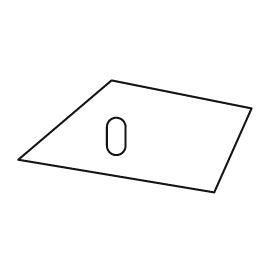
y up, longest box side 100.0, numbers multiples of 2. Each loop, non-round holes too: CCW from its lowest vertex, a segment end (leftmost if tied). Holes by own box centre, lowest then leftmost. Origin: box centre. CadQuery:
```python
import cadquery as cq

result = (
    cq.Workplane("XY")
    .moveTo(34.0, -24.0)
    .lineTo(50.0, 12.0)
    .lineTo(-10.0, 24.0)
    .lineTo(-50.0, -10.0)
    .close()
    .moveTo(-12.0, -4.0)
    .threePointArc((-8.0, -8.0), (-4.0, -4.0))
    .lineTo(-4.0, 4.0)
    .threePointArc((-8.0, 8.0), (-12.0, 4.0))
    .close()
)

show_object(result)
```